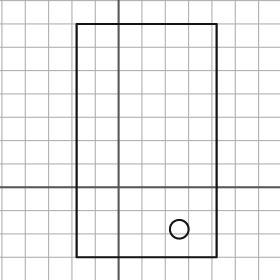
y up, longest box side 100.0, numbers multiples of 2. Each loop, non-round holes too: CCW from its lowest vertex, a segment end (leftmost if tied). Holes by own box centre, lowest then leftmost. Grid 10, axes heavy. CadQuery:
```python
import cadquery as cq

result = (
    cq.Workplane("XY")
    .moveTo(-18.0, -30.0)
    .lineTo(42.0, -30.0)
    .lineTo(42.0, 70.0)
    .lineTo(-18.0, 70.0)
    .close()
    .moveTo(26.0, -18.0)
    .circle(4.0)
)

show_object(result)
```